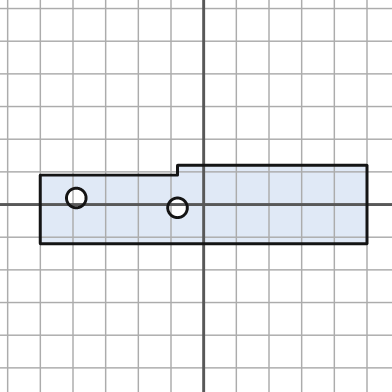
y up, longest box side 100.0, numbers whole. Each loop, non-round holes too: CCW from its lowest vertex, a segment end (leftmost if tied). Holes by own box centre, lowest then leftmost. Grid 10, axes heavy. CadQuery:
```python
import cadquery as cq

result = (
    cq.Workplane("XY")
    .moveTo(-50.0, -12.0)
    .lineTo(50.0, -12.0)
    .lineTo(50.0, 12.0)
    .lineTo(-8.0, 12.0)
    .lineTo(-8.0, 9.0)
    .lineTo(-50.0, 9.0)
    .close()
    .moveTo(-8.0, -1.0)
    .circle(3.0)
    .moveTo(-39.0, 2.0)
    .circle(3.0)
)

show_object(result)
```